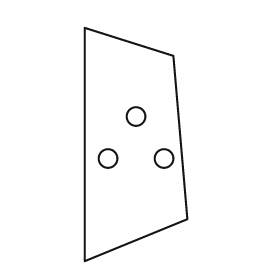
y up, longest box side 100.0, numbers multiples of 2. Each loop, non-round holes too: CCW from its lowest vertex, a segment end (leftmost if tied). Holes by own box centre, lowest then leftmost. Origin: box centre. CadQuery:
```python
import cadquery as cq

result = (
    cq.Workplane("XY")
    .moveTo(-22.0, -50.0)
    .lineTo(22.0, -32.0)
    .lineTo(16.0, 38.0)
    .lineTo(-22.0, 50.0)
    .close()
    .moveTo(-12.0, -6.0)
    .circle(4.0)
    .moveTo(12.0, -6.0)
    .circle(4.0)
    .moveTo(0.0, 12.0)
    .circle(4.0)
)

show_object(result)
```